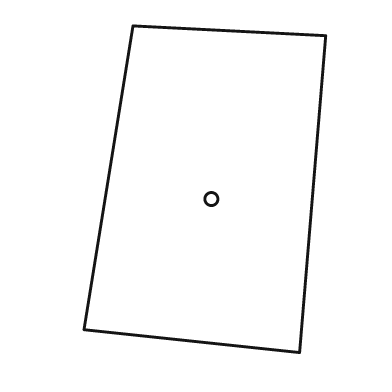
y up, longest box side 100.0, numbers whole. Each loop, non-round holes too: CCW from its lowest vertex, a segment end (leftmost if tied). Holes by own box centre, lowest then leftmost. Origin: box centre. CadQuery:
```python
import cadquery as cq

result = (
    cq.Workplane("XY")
    .moveTo(29.0, -50.0)
    .lineTo(37.0, 47.0)
    .lineTo(-22.0, 50.0)
    .lineTo(-37.0, -43.0)
    .close()
    .moveTo(2.0, -3.0)
    .circle(2.0)
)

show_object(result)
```